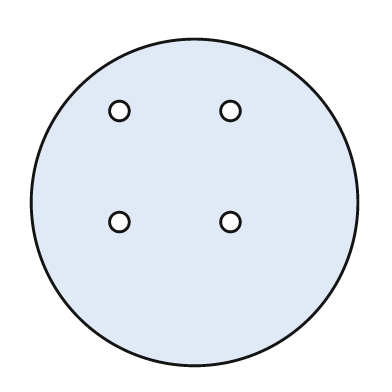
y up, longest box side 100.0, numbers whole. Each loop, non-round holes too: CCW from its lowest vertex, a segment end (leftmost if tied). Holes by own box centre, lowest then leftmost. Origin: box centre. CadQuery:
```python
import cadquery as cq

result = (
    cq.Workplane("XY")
    .moveTo(0.0, 0.0)
    .circle(50.0)
    .moveTo(-23.0, -6.0)
    .circle(3.0)
    .moveTo(11.0, -6.0)
    .circle(3.0)
    .moveTo(-23.0, 28.0)
    .circle(3.0)
    .moveTo(11.0, 28.0)
    .circle(3.0)
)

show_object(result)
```